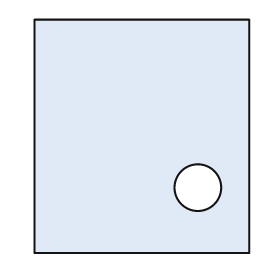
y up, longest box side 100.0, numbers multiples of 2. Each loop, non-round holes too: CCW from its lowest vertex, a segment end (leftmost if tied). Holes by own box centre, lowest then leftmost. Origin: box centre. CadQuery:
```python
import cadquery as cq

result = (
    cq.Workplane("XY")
    .moveTo(-46.0, -50.0)
    .lineTo(46.0, -50.0)
    .lineTo(46.0, 50.0)
    .lineTo(-46.0, 50.0)
    .close()
    .moveTo(24.0, -22.0)
    .circle(10.0)
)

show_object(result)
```